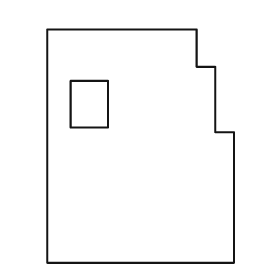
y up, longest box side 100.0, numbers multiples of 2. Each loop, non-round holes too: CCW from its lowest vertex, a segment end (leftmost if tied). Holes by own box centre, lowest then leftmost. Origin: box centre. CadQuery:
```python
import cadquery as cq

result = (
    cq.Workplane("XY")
    .moveTo(-40.0, -50.0)
    .lineTo(40.0, -50.0)
    .lineTo(40.0, 6.0)
    .lineTo(32.0, 6.0)
    .lineTo(32.0, 34.0)
    .lineTo(24.0, 34.0)
    .lineTo(24.0, 50.0)
    .lineTo(-40.0, 50.0)
    .close()
    .moveTo(-30.0, 8.0)
    .lineTo(-14.0, 8.0)
    .lineTo(-14.0, 28.0)
    .lineTo(-30.0, 28.0)
    .close()
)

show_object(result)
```